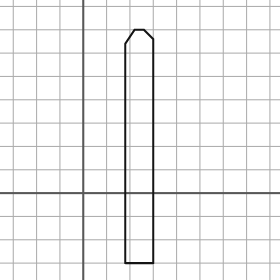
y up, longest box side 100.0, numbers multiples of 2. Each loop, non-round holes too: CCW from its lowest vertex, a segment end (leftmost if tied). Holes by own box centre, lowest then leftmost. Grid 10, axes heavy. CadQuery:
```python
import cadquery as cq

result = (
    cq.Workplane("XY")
    .moveTo(18.0, -30.0)
    .lineTo(30.0, -30.0)
    .lineTo(30.0, 66.0)
    .lineTo(26.0, 70.0)
    .lineTo(22.0, 70.0)
    .lineTo(18.0, 64.0)
    .close()
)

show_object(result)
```